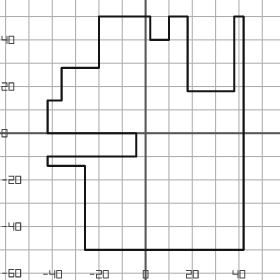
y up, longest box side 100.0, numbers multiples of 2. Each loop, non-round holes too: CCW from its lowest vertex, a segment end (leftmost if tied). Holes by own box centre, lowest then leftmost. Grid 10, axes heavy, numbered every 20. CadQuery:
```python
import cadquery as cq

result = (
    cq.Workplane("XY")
    .moveTo(-26.0, -50.0)
    .lineTo(42.0, -50.0)
    .lineTo(42.0, 50.0)
    .lineTo(38.0, 50.0)
    .lineTo(38.0, 18.0)
    .lineTo(18.0, 18.0)
    .lineTo(18.0, 50.0)
    .lineTo(10.0, 50.0)
    .lineTo(10.0, 40.0)
    .lineTo(2.0, 40.0)
    .lineTo(2.0, 50.0)
    .lineTo(-20.0, 50.0)
    .lineTo(-20.0, 28.0)
    .lineTo(-36.0, 28.0)
    .lineTo(-36.0, 14.0)
    .lineTo(-42.0, 14.0)
    .lineTo(-42.0, 0.0)
    .lineTo(-4.0, 0.0)
    .lineTo(-4.0, -10.0)
    .lineTo(-42.0, -10.0)
    .lineTo(-42.0, -14.0)
    .lineTo(-26.0, -14.0)
    .close()
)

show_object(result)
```